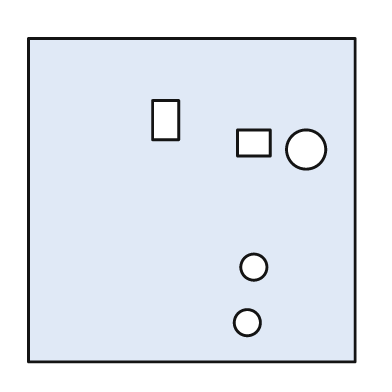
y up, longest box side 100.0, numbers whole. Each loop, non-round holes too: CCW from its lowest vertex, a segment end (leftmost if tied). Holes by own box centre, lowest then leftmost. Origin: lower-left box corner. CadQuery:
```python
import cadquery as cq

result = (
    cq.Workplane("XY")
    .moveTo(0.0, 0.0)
    .lineTo(100.0, 0.0)
    .lineTo(100.0, 99.0)
    .lineTo(0.0, 99.0)
    .close()
    .moveTo(67.0, 12.0)
    .circle(4.0)
    .moveTo(69.0, 29.0)
    .circle(4.0)
    .moveTo(85.0, 65.0)
    .circle(6.0)
    .moveTo(64.0, 63.0)
    .lineTo(74.0, 63.0)
    .lineTo(74.0, 71.0)
    .lineTo(64.0, 71.0)
    .close()
    .moveTo(38.0, 68.0)
    .lineTo(46.0, 68.0)
    .lineTo(46.0, 80.0)
    .lineTo(38.0, 80.0)
    .close()
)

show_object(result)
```